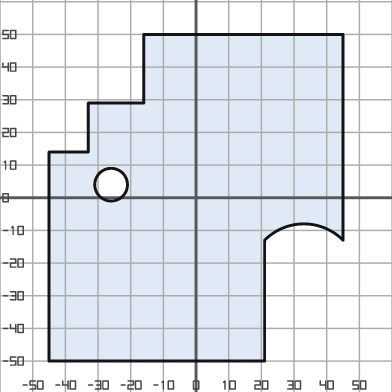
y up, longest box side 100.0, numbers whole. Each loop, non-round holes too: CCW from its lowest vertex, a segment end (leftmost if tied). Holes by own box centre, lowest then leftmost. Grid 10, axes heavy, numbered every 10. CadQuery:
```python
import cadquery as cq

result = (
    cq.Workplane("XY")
    .moveTo(-45.0, -50.0)
    .lineTo(21.0, -50.0)
    .lineTo(21.0, -13.0)
    .threePointArc((33.0, -8.0), (45.0, -13.0))
    .lineTo(45.0, 50.0)
    .lineTo(-16.0, 50.0)
    .lineTo(-16.0, 29.0)
    .lineTo(-33.0, 29.0)
    .lineTo(-33.0, 14.0)
    .lineTo(-45.0, 14.0)
    .close()
    .moveTo(-26.0, 4.0)
    .circle(5.0)
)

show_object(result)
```